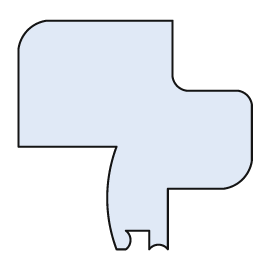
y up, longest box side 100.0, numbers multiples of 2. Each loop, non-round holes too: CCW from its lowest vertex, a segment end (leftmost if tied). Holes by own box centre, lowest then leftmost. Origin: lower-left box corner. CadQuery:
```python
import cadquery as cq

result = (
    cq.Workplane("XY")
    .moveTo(42.0, 0.0)
    .lineTo(46.0, 0.0)
    .threePointArc((48.0, 4.0), (46.0, 8.0))
    .lineTo(56.0, 8.0)
    .lineTo(56.0, 0.0)
    .threePointArc((60.0, 2.0), (64.0, 0.0))
    .lineTo(64.0, 26.0)
    .lineTo(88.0, 26.0)
    .threePointArc((96.0, 30.0), (100.0, 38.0))
    .lineTo(100.0, 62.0)
    .threePointArc((98.0, 66.0), (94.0, 68.0))
    .lineTo(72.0, 68.0)
    .threePointArc((68.0, 70.0), (66.0, 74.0))
    .lineTo(66.0, 98.0)
    .lineTo(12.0, 98.0)
    .threePointArc((4.0, 94.0), (0.0, 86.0))
    .lineTo(0.0, 44.0)
    .lineTo(42.0, 44.0)
    .threePointArc((38.0, 22.0), (42.0, 0.0))
    .close()
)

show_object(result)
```